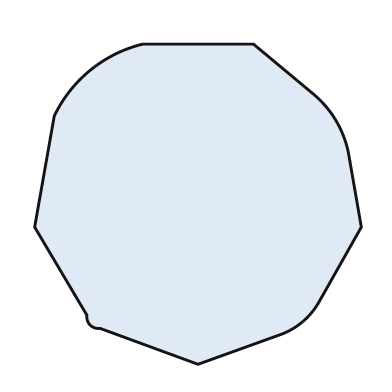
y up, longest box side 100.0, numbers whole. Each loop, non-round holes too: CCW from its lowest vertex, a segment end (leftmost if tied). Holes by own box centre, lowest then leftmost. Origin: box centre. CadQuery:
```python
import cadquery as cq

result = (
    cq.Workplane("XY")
    .moveTo(0.0, -49.0)
    .lineTo(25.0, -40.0)
    .threePointArc((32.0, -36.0), (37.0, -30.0))
    .lineTo(50.0, -7.0)
    .lineTo(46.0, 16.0)
    .threePointArc((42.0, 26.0), (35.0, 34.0))
    .lineTo(17.0, 49.0)
    .lineTo(-17.0, 49.0)
    .threePointArc((-33.0, 41.0), (-44.0, 27.0))
    .lineTo(-50.0, -7.0)
    .lineTo(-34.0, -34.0)
    .threePointArc((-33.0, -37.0), (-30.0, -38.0))
    .close()
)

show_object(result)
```